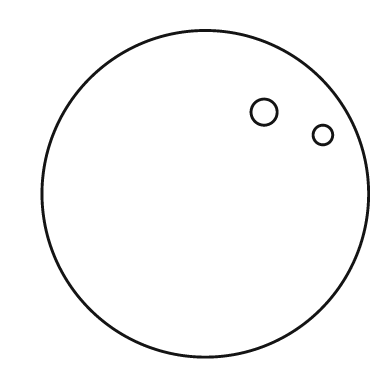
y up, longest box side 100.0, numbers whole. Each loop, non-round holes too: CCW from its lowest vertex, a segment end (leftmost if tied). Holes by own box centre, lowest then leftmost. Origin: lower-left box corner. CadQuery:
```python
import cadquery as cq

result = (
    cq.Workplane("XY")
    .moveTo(50.0, 50.0)
    .circle(50.0)
    .moveTo(86.0, 68.0)
    .circle(3.0)
    .moveTo(68.0, 75.0)
    .circle(4.0)
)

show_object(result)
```